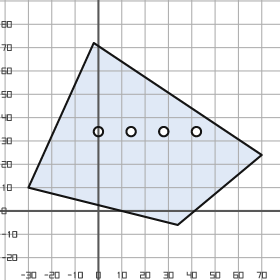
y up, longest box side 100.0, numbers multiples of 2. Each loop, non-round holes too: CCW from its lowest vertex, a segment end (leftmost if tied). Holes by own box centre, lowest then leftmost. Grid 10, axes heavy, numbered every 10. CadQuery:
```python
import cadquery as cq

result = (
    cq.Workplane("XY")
    .moveTo(34.0, -6.0)
    .lineTo(70.0, 24.0)
    .lineTo(-2.0, 72.0)
    .lineTo(-30.0, 10.0)
    .close()
    .moveTo(0.0, 34.0)
    .circle(2.0)
    .moveTo(14.0, 34.0)
    .circle(2.0)
    .moveTo(28.0, 34.0)
    .circle(2.0)
    .moveTo(42.0, 34.0)
    .circle(2.0)
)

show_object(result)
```